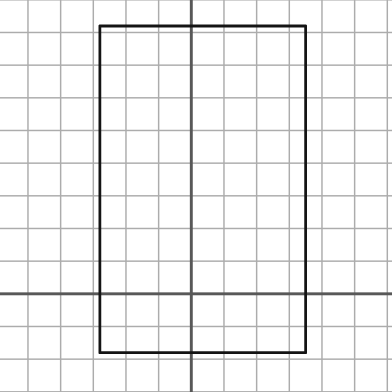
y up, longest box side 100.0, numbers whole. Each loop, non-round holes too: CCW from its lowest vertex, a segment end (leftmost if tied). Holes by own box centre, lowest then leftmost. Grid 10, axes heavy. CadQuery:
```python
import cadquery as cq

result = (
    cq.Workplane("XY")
    .moveTo(-28.0, -18.0)
    .lineTo(35.0, -18.0)
    .lineTo(35.0, 82.0)
    .lineTo(-28.0, 82.0)
    .close()
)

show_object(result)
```